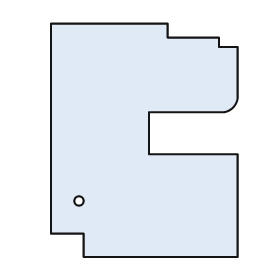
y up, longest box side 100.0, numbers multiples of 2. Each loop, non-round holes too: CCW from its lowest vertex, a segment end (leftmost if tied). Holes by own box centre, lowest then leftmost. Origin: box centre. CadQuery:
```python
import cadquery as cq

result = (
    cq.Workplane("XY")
    .moveTo(-26.0, -50.0)
    .lineTo(40.0, -50.0)
    .lineTo(40.0, -6.0)
    .lineTo(2.0, -6.0)
    .lineTo(2.0, 12.0)
    .lineTo(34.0, 12.0)
    .threePointArc((38.0, 14.0), (40.0, 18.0))
    .lineTo(40.0, 40.0)
    .lineTo(32.0, 40.0)
    .lineTo(32.0, 44.0)
    .lineTo(10.0, 44.0)
    .lineTo(10.0, 50.0)
    .lineTo(-40.0, 50.0)
    .lineTo(-40.0, -40.0)
    .lineTo(-26.0, -40.0)
    .close()
    .moveTo(-28.0, -26.0)
    .circle(2.0)
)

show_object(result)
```